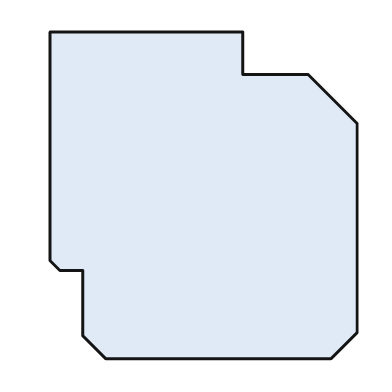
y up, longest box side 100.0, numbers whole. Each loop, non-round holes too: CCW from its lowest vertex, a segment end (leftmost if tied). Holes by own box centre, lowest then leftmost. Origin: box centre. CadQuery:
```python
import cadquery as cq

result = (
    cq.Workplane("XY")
    .moveTo(-30.0, -50.0)
    .lineTo(39.0, -50.0)
    .lineTo(47.0, -42.0)
    .lineTo(47.0, 22.0)
    .lineTo(32.0, 37.0)
    .lineTo(12.0, 37.0)
    .lineTo(12.0, 50.0)
    .lineTo(-47.0, 50.0)
    .lineTo(-47.0, -20.0)
    .lineTo(-44.0, -23.0)
    .lineTo(-37.0, -23.0)
    .lineTo(-37.0, -43.0)
    .close()
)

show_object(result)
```